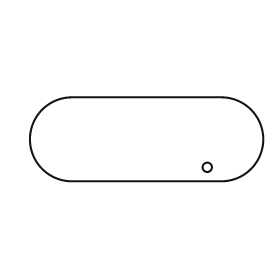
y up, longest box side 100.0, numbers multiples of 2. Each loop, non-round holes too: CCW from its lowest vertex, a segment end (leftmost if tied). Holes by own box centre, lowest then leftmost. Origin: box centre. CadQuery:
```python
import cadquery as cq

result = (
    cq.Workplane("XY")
    .moveTo(-32.0, -18.0)
    .lineTo(32.0, -18.0)
    .threePointArc((50.0, 0.0), (32.0, 18.0))
    .lineTo(-32.0, 18.0)
    .threePointArc((-50.0, 0.0), (-32.0, -18.0))
    .close()
    .moveTo(26.0, -12.0)
    .circle(2.0)
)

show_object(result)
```